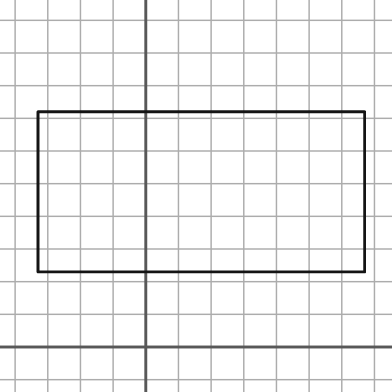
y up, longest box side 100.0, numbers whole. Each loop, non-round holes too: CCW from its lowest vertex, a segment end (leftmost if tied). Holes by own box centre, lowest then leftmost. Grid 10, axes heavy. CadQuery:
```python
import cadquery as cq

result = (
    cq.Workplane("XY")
    .moveTo(-33.0, 23.0)
    .lineTo(67.0, 23.0)
    .lineTo(67.0, 72.0)
    .lineTo(-33.0, 72.0)
    .close()
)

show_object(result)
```